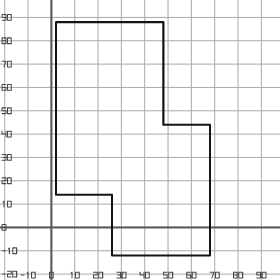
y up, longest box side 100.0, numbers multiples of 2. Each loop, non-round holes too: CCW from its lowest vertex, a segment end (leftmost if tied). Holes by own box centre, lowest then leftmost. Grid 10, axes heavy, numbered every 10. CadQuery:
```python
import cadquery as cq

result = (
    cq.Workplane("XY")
    .moveTo(26.0, -12.0)
    .lineTo(68.0, -12.0)
    .lineTo(68.0, 44.0)
    .lineTo(48.0, 44.0)
    .lineTo(48.0, 88.0)
    .lineTo(2.0, 88.0)
    .lineTo(2.0, 14.0)
    .lineTo(26.0, 14.0)
    .close()
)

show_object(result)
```